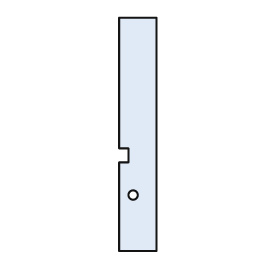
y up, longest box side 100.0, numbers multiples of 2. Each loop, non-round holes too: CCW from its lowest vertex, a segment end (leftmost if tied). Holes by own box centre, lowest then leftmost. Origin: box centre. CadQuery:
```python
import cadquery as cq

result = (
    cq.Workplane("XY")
    .moveTo(-8.0, -50.0)
    .lineTo(8.0, -50.0)
    .lineTo(8.0, 50.0)
    .lineTo(-8.0, 50.0)
    .lineTo(-8.0, -6.0)
    .lineTo(-4.0, -6.0)
    .lineTo(-4.0, -12.0)
    .lineTo(-8.0, -12.0)
    .close()
    .moveTo(-2.0, -26.0)
    .circle(2.0)
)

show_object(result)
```